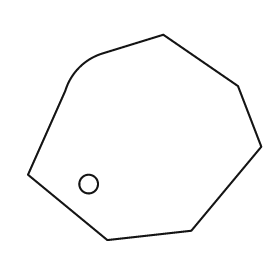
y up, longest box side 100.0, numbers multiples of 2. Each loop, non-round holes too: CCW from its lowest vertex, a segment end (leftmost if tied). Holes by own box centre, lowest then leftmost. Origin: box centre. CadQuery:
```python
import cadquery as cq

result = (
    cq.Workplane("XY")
    .moveTo(-16.0, -44.0)
    .lineTo(20.0, -40.0)
    .lineTo(50.0, -4.0)
    .lineTo(40.0, 22.0)
    .lineTo(8.0, 44.0)
    .lineTo(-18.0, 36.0)
    .threePointArc((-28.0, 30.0), (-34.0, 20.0))
    .lineTo(-50.0, -16.0)
    .close()
    .moveTo(-24.0, -20.0)
    .circle(4.0)
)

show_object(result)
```